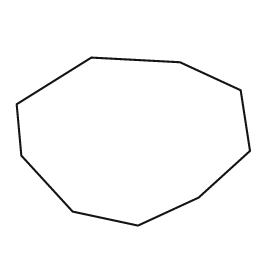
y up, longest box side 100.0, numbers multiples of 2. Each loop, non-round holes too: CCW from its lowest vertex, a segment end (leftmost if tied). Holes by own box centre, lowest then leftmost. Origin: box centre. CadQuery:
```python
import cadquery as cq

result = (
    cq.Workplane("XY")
    .moveTo(2.0, -36.0)
    .lineTo(28.0, -24.0)
    .lineTo(50.0, -4.0)
    .lineTo(46.0, 22.0)
    .lineTo(20.0, 34.0)
    .lineTo(-18.0, 36.0)
    .lineTo(-50.0, 16.0)
    .lineTo(-48.0, -6.0)
    .lineTo(-26.0, -30.0)
    .close()
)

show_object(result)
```